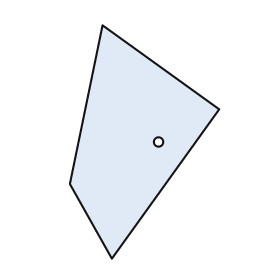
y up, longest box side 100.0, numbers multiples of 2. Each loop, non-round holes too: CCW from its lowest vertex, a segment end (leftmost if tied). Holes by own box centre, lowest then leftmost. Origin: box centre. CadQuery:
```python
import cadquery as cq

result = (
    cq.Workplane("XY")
    .moveTo(-14.0, -50.0)
    .lineTo(32.0, 14.0)
    .lineTo(-18.0, 50.0)
    .lineTo(-32.0, -18.0)
    .close()
    .moveTo(6.0, 0.0)
    .circle(2.0)
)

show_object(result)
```